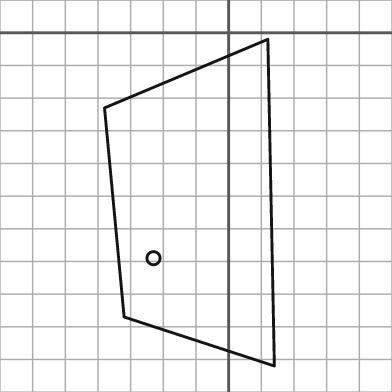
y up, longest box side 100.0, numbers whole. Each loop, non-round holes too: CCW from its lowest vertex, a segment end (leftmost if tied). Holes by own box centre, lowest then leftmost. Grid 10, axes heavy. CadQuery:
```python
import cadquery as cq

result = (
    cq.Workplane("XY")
    .moveTo(14.0, -102.0)
    .lineTo(12.0, -2.0)
    .lineTo(-38.0, -23.0)
    .lineTo(-32.0, -87.0)
    .close()
    .moveTo(-23.0, -69.0)
    .circle(2.0)
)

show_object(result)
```